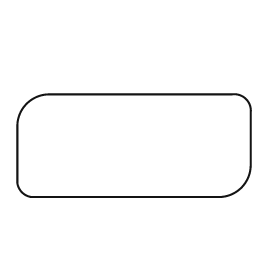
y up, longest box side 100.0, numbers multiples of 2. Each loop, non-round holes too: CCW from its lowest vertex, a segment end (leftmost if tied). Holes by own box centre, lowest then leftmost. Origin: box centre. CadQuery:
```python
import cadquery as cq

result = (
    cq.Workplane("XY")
    .moveTo(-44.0, -22.0)
    .lineTo(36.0, -22.0)
    .threePointArc((46.0, -18.0), (50.0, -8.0))
    .lineTo(50.0, 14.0)
    .threePointArc((48.0, 20.0), (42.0, 22.0))
    .lineTo(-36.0, 22.0)
    .threePointArc((-46.0, 18.0), (-50.0, 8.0))
    .lineTo(-50.0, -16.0)
    .threePointArc((-48.0, -20.0), (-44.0, -22.0))
    .close()
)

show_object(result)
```